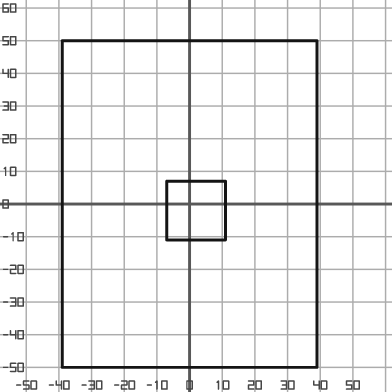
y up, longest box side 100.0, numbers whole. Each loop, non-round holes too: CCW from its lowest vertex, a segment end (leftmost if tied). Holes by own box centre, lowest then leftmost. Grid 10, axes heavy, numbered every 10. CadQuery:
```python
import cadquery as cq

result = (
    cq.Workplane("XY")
    .moveTo(-39.0, -50.0)
    .lineTo(39.0, -50.0)
    .lineTo(39.0, 50.0)
    .lineTo(-39.0, 50.0)
    .close()
    .moveTo(-7.0, -11.0)
    .lineTo(11.0, -11.0)
    .lineTo(11.0, 7.0)
    .lineTo(-7.0, 7.0)
    .close()
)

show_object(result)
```